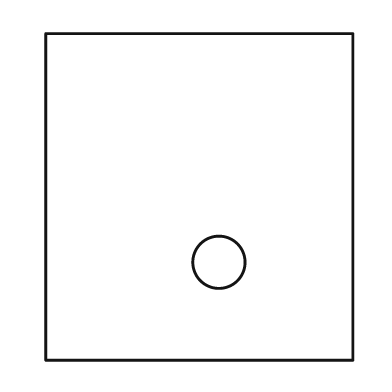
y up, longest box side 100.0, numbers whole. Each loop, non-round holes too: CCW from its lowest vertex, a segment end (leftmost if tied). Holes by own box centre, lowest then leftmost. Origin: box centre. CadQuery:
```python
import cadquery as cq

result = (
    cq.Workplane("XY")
    .moveTo(-47.0, -50.0)
    .lineTo(47.0, -50.0)
    .lineTo(47.0, 50.0)
    .lineTo(-47.0, 50.0)
    .close()
    .moveTo(6.0, -20.0)
    .circle(8.0)
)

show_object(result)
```